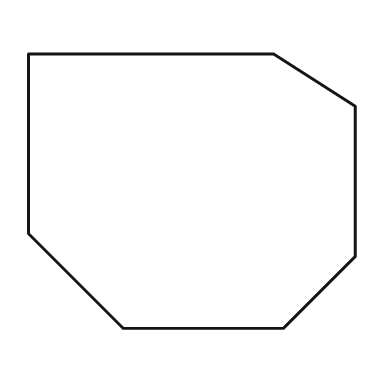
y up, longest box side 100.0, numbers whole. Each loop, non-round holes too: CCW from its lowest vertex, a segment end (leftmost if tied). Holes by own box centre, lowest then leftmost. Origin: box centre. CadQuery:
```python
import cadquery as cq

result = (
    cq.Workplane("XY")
    .moveTo(-21.0, -42.0)
    .lineTo(28.0, -42.0)
    .lineTo(50.0, -20.0)
    .lineTo(50.0, 26.0)
    .lineTo(25.0, 42.0)
    .lineTo(-50.0, 42.0)
    .lineTo(-50.0, -13.0)
    .close()
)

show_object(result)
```